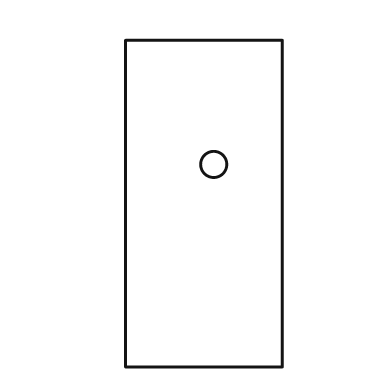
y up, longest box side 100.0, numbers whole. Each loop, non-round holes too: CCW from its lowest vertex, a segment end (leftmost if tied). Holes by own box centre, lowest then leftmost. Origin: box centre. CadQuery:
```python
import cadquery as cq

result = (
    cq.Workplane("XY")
    .moveTo(-24.0, -50.0)
    .lineTo(24.0, -50.0)
    .lineTo(24.0, 50.0)
    .lineTo(-24.0, 50.0)
    .close()
    .moveTo(3.0, 12.0)
    .circle(4.0)
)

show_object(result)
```